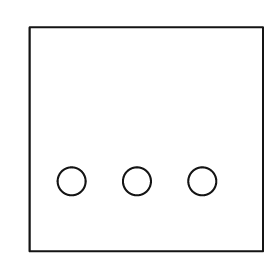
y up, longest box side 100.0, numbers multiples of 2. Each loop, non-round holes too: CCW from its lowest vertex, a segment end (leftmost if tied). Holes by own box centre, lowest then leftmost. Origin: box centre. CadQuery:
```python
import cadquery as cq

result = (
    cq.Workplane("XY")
    .moveTo(-50.0, -48.0)
    .lineTo(50.0, -48.0)
    .lineTo(50.0, 48.0)
    .lineTo(-50.0, 48.0)
    .close()
    .moveTo(-32.0, -18.0)
    .circle(6.0)
    .moveTo(-4.0, -18.0)
    .circle(6.0)
    .moveTo(24.0, -18.0)
    .circle(6.0)
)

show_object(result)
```